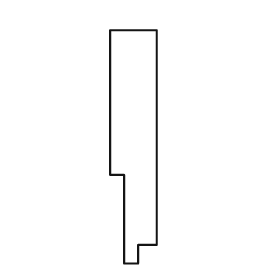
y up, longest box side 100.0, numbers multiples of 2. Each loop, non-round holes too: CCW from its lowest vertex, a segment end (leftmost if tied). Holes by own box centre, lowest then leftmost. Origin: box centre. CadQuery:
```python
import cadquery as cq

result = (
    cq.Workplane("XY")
    .moveTo(-4.0, -50.0)
    .lineTo(2.0, -50.0)
    .lineTo(2.0, -42.0)
    .lineTo(10.0, -42.0)
    .lineTo(10.0, 50.0)
    .lineTo(-10.0, 50.0)
    .lineTo(-10.0, -12.0)
    .lineTo(-4.0, -12.0)
    .close()
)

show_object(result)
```